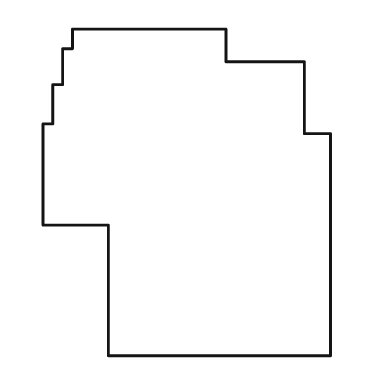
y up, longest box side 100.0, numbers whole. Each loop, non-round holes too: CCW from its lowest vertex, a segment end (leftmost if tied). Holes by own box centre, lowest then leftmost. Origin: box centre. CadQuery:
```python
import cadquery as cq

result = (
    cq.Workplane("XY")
    .moveTo(-24.0, -50.0)
    .lineTo(44.0, -50.0)
    .lineTo(44.0, 18.0)
    .lineTo(36.0, 18.0)
    .lineTo(36.0, 40.0)
    .lineTo(12.0, 40.0)
    .lineTo(12.0, 50.0)
    .lineTo(-35.0, 50.0)
    .lineTo(-35.0, 44.0)
    .lineTo(-38.0, 44.0)
    .lineTo(-38.0, 33.0)
    .lineTo(-41.0, 33.0)
    .lineTo(-41.0, 21.0)
    .lineTo(-44.0, 21.0)
    .lineTo(-44.0, -10.0)
    .lineTo(-24.0, -10.0)
    .close()
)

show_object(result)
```